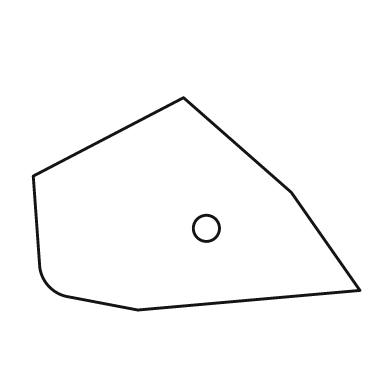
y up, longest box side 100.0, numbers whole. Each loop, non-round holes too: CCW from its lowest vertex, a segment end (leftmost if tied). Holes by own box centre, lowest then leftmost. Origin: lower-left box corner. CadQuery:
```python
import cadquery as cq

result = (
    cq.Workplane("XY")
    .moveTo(32.0, 0.0)
    .lineTo(100.0, 6.0)
    .lineTo(79.0, 36.0)
    .lineTo(46.0, 65.0)
    .lineTo(0.0, 41.0)
    .lineTo(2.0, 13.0)
    .threePointArc((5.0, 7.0), (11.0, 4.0))
    .close()
    .moveTo(53.0, 25.0)
    .circle(4.0)
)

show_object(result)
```